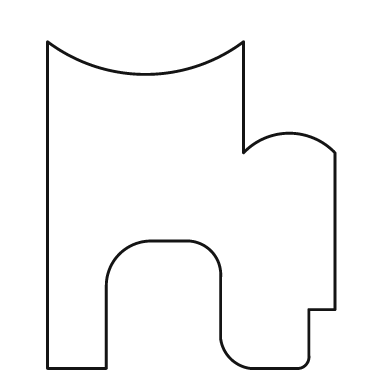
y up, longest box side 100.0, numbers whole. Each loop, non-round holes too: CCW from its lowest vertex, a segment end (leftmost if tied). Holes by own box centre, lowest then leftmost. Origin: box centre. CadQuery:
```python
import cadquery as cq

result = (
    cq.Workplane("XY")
    .moveTo(-44.0, -50.0)
    .lineTo(-26.0, -50.0)
    .lineTo(-26.0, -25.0)
    .threePointArc((-22.0, -15.0), (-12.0, -11.0))
    .lineTo(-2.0, -11.0)
    .threePointArc((6.0, -14.0), (9.0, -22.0))
    .lineTo(9.0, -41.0)
    .threePointArc((12.0, -47.0), (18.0, -50.0))
    .lineTo(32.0, -50.0)
    .threePointArc((35.0, -49.0), (36.0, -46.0))
    .lineTo(36.0, -32.0)
    .lineTo(44.0, -32.0)
    .lineTo(44.0, 16.0)
    .threePointArc((30.0, 22.0), (16.0, 16.0))
    .lineTo(16.0, 50.0)
    .threePointArc((-14.0, 40.0), (-44.0, 50.0))
    .close()
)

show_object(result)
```